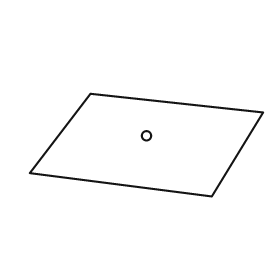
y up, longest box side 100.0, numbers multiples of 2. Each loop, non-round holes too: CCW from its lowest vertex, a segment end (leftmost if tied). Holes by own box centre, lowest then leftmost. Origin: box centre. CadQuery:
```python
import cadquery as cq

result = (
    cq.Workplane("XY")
    .moveTo(28.0, -22.0)
    .lineTo(50.0, 14.0)
    .lineTo(-24.0, 22.0)
    .lineTo(-50.0, -12.0)
    .close()
    .moveTo(0.0, 4.0)
    .circle(2.0)
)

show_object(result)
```